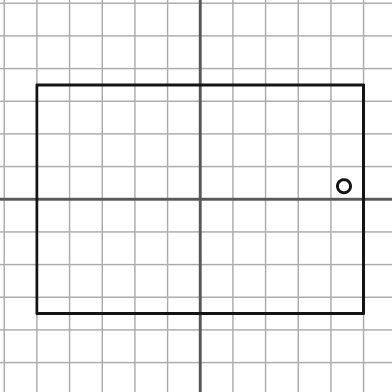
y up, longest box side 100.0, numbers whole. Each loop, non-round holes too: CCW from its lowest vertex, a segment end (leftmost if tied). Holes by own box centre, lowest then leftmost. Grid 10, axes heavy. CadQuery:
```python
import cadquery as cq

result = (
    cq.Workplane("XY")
    .moveTo(-50.0, -35.0)
    .lineTo(50.0, -35.0)
    .lineTo(50.0, 35.0)
    .lineTo(-50.0, 35.0)
    .close()
    .moveTo(44.0, 4.0)
    .circle(2.0)
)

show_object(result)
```